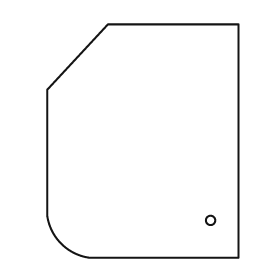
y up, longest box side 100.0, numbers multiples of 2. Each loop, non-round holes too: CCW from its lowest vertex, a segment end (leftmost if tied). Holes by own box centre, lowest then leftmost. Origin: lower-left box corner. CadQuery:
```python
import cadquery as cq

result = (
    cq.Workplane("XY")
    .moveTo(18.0, 0.0)
    .lineTo(82.0, 0.0)
    .lineTo(82.0, 100.0)
    .lineTo(26.0, 100.0)
    .lineTo(0.0, 72.0)
    .lineTo(0.0, 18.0)
    .threePointArc((6.0, 6.0), (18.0, 0.0))
    .close()
    .moveTo(70.0, 16.0)
    .circle(2.0)
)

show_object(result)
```